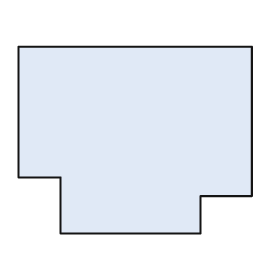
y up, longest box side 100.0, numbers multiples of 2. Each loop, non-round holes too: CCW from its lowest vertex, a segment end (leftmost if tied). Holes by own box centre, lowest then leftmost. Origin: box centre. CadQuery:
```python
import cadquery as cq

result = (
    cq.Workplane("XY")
    .moveTo(-32.0, -40.0)
    .lineTo(28.0, -40.0)
    .lineTo(28.0, -24.0)
    .lineTo(50.0, -24.0)
    .lineTo(50.0, 40.0)
    .lineTo(-50.0, 40.0)
    .lineTo(-50.0, -16.0)
    .lineTo(-32.0, -16.0)
    .close()
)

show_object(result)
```